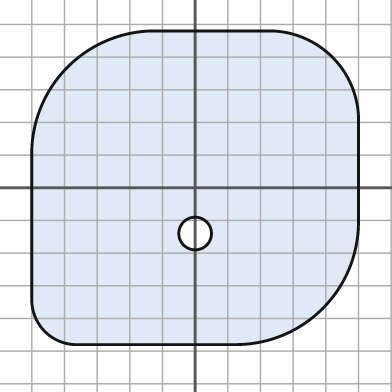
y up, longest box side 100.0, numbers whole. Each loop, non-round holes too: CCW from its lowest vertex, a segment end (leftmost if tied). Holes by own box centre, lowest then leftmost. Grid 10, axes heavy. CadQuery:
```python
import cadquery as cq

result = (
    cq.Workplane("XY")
    .moveTo(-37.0, -48.0)
    .lineTo(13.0, -48.0)
    .threePointArc((39.0, -37.0), (50.0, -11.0))
    .lineTo(50.0, 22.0)
    .threePointArc((42.0, 40.0), (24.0, 48.0))
    .lineTo(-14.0, 48.0)
    .threePointArc((-39.0, 37.0), (-50.0, 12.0))
    .lineTo(-50.0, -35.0)
    .threePointArc((-46.0, -44.0), (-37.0, -48.0))
    .close()
    .moveTo(0.0, -14.0)
    .circle(5.0)
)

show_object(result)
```